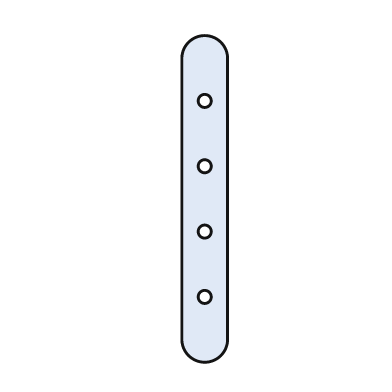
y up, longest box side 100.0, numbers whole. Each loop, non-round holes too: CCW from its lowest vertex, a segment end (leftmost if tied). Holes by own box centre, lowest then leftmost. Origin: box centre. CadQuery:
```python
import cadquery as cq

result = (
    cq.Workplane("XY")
    .moveTo(-7.0, -43.0)
    .threePointArc((0.0, -50.0), (7.0, -43.0))
    .lineTo(7.0, 43.0)
    .threePointArc((0.0, 50.0), (-7.0, 43.0))
    .close()
    .moveTo(0.0, -30.0)
    .circle(2.0)
    .moveTo(0.0, -10.0)
    .circle(2.0)
    .moveTo(0.0, 10.0)
    .circle(2.0)
    .moveTo(0.0, 30.0)
    .circle(2.0)
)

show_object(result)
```